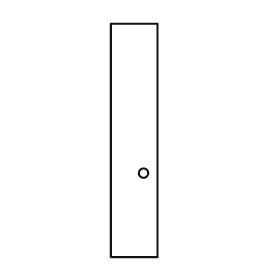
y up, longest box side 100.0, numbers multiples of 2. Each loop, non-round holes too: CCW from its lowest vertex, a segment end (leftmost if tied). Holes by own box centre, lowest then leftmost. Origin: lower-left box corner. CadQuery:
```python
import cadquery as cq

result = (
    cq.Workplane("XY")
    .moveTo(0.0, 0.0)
    .lineTo(20.0, 0.0)
    .lineTo(20.0, 100.0)
    .lineTo(0.0, 100.0)
    .close()
    .moveTo(14.0, 36.0)
    .circle(2.0)
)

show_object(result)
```